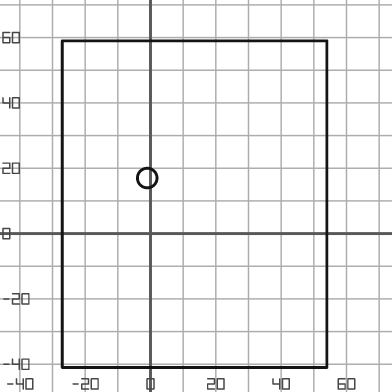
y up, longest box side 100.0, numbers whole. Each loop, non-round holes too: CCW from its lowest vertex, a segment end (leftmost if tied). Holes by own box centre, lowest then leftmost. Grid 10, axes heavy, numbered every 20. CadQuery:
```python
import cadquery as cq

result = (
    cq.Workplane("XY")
    .moveTo(-27.0, -41.0)
    .lineTo(54.0, -41.0)
    .lineTo(54.0, 59.0)
    .lineTo(-27.0, 59.0)
    .close()
    .moveTo(-1.0, 17.0)
    .circle(3.0)
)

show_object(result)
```